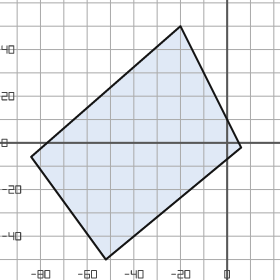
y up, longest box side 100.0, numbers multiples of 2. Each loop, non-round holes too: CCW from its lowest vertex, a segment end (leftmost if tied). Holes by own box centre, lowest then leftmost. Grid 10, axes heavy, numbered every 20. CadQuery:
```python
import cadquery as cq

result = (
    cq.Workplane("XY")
    .moveTo(-52.0, -50.0)
    .lineTo(6.0, -2.0)
    .lineTo(-20.0, 50.0)
    .lineTo(-84.0, -6.0)
    .close()
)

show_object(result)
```